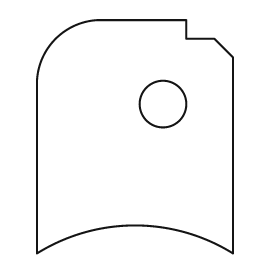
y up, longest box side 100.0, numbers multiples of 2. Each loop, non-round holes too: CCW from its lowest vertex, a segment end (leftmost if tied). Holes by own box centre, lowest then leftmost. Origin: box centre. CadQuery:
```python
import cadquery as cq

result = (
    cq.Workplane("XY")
    .moveTo(-42.0, -50.0)
    .threePointArc((0.0, -38.0), (42.0, -50.0))
    .lineTo(42.0, 34.0)
    .lineTo(34.0, 42.0)
    .lineTo(22.0, 42.0)
    .lineTo(22.0, 50.0)
    .lineTo(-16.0, 50.0)
    .threePointArc((-34.0, 42.0), (-42.0, 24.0))
    .close()
    .moveTo(12.0, 14.0)
    .circle(10.0)
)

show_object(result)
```